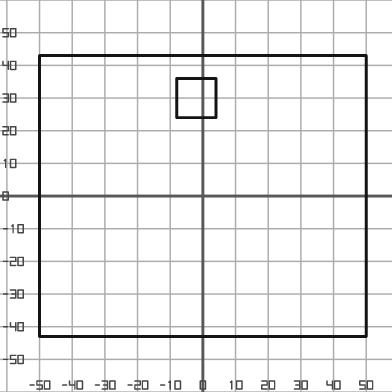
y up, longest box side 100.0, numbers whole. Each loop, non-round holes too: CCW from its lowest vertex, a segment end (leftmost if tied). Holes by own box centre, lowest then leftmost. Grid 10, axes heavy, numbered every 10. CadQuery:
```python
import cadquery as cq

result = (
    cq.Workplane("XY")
    .moveTo(-50.0, -43.0)
    .lineTo(50.0, -43.0)
    .lineTo(50.0, 43.0)
    .lineTo(-50.0, 43.0)
    .close()
    .moveTo(-8.0, 24.0)
    .lineTo(4.0, 24.0)
    .lineTo(4.0, 36.0)
    .lineTo(-8.0, 36.0)
    .close()
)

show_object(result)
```